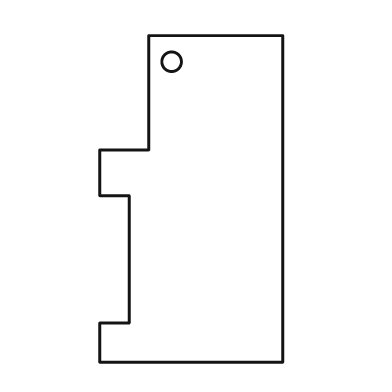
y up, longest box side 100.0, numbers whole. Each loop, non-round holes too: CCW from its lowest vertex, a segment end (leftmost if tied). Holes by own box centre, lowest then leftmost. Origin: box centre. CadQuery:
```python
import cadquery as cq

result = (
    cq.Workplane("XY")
    .moveTo(-28.0, -50.0)
    .lineTo(28.0, -50.0)
    .lineTo(28.0, 50.0)
    .lineTo(-13.0, 50.0)
    .lineTo(-13.0, 15.0)
    .lineTo(-28.0, 15.0)
    .lineTo(-28.0, 1.0)
    .lineTo(-19.0, 1.0)
    .lineTo(-19.0, -38.0)
    .lineTo(-28.0, -38.0)
    .close()
    .moveTo(-6.0, 42.0)
    .circle(3.0)
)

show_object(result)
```